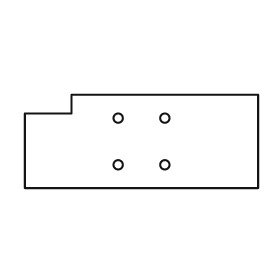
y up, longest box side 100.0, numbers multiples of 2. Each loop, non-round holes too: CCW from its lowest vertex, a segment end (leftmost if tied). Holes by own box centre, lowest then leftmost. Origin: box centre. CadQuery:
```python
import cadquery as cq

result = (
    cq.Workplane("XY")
    .moveTo(-50.0, -20.0)
    .lineTo(50.0, -20.0)
    .lineTo(50.0, 20.0)
    .lineTo(-30.0, 20.0)
    .lineTo(-30.0, 12.0)
    .lineTo(-50.0, 12.0)
    .close()
    .moveTo(-10.0, -10.0)
    .circle(2.0)
    .moveTo(10.0, -10.0)
    .circle(2.0)
    .moveTo(-10.0, 10.0)
    .circle(2.0)
    .moveTo(10.0, 10.0)
    .circle(2.0)
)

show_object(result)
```